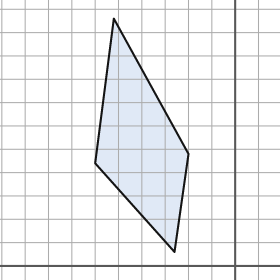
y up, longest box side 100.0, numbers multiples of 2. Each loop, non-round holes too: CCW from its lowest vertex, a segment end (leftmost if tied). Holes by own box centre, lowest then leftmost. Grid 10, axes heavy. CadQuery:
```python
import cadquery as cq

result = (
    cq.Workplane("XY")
    .moveTo(-26.0, 6.0)
    .lineTo(-20.0, 48.0)
    .lineTo(-52.0, 106.0)
    .lineTo(-60.0, 44.0)
    .close()
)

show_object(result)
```